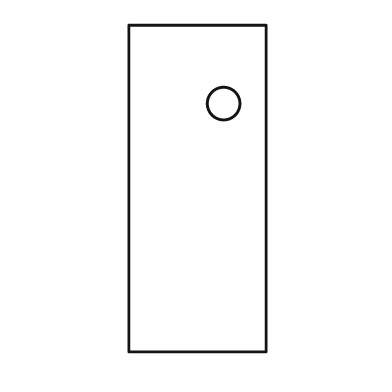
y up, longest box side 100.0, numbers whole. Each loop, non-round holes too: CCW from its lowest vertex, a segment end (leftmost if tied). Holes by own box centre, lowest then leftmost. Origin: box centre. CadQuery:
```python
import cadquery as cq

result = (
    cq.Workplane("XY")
    .moveTo(-21.0, -50.0)
    .lineTo(21.0, -50.0)
    .lineTo(21.0, 50.0)
    .lineTo(-21.0, 50.0)
    .close()
    .moveTo(8.0, 26.0)
    .circle(5.0)
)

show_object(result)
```